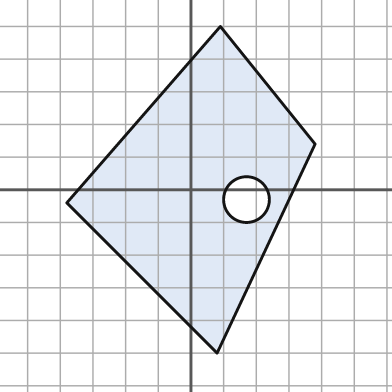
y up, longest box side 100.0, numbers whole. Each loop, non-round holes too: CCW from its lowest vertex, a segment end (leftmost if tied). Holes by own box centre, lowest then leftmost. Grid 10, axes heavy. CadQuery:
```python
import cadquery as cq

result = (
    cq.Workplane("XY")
    .moveTo(8.0, -50.0)
    .lineTo(38.0, 14.0)
    .lineTo(9.0, 50.0)
    .lineTo(-38.0, -4.0)
    .close()
    .moveTo(17.0, -3.0)
    .circle(7.0)
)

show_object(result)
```